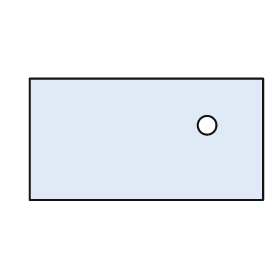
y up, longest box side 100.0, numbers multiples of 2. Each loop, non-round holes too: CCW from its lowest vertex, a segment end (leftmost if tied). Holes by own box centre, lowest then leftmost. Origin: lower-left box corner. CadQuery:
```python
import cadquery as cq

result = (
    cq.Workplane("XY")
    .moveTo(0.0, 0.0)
    .lineTo(100.0, 0.0)
    .lineTo(100.0, 52.0)
    .lineTo(0.0, 52.0)
    .close()
    .moveTo(76.0, 32.0)
    .circle(4.0)
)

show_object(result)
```